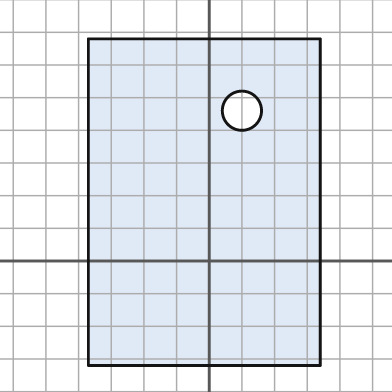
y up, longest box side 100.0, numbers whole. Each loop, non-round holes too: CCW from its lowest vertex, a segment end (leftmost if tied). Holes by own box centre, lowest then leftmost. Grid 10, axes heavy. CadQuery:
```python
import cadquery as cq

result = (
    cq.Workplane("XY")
    .moveTo(-37.0, -32.0)
    .lineTo(34.0, -32.0)
    .lineTo(34.0, 68.0)
    .lineTo(-37.0, 68.0)
    .close()
    .moveTo(10.0, 46.0)
    .circle(6.0)
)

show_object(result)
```